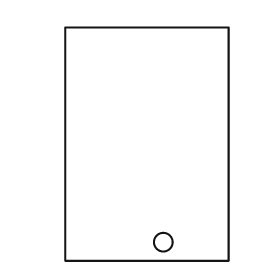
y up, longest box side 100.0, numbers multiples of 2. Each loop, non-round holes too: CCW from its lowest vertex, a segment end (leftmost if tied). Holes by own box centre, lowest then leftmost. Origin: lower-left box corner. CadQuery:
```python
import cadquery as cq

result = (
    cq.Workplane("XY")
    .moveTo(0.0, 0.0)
    .lineTo(70.0, 0.0)
    .lineTo(70.0, 100.0)
    .lineTo(0.0, 100.0)
    .close()
    .moveTo(42.0, 8.0)
    .circle(4.0)
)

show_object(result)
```